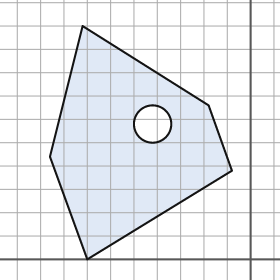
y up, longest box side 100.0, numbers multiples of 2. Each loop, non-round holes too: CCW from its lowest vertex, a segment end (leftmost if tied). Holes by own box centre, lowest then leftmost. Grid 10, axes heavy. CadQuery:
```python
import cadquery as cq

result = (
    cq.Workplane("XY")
    .moveTo(-70.0, 0.0)
    .lineTo(-8.0, 38.0)
    .lineTo(-18.0, 66.0)
    .lineTo(-72.0, 100.0)
    .lineTo(-86.0, 44.0)
    .close()
    .moveTo(-42.0, 58.0)
    .circle(8.0)
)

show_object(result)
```